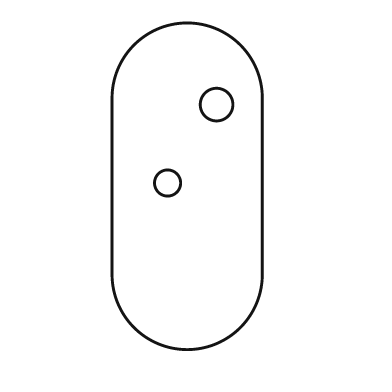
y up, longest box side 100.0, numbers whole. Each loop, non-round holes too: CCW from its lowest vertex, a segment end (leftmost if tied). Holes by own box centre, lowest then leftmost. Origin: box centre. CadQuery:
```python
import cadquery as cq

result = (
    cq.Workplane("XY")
    .moveTo(-23.0, -27.0)
    .threePointArc((0.0, -50.0), (23.0, -27.0))
    .lineTo(23.0, 27.0)
    .threePointArc((0.0, 50.0), (-23.0, 27.0))
    .close()
    .moveTo(-6.0, 1.0)
    .circle(4.0)
    .moveTo(9.0, 25.0)
    .circle(5.0)
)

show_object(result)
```